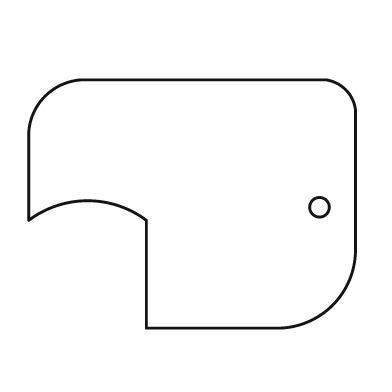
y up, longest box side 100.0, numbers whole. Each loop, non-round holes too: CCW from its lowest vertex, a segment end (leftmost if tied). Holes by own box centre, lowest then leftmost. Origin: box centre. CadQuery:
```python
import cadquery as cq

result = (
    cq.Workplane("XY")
    .moveTo(-14.0, -38.0)
    .lineTo(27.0, -38.0)
    .threePointArc((43.0, -31.0), (50.0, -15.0))
    .lineTo(50.0, 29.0)
    .threePointArc((47.0, 35.0), (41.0, 38.0))
    .lineTo(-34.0, 38.0)
    .threePointArc((-45.0, 33.0), (-50.0, 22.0))
    .lineTo(-50.0, -5.0)
    .threePointArc((-32.0, 1.0), (-14.0, -5.0))
    .close()
    .moveTo(39.0, -1.0)
    .circle(3.0)
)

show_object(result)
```